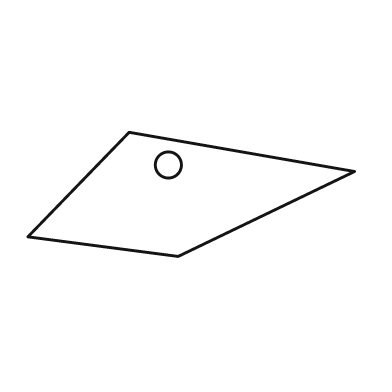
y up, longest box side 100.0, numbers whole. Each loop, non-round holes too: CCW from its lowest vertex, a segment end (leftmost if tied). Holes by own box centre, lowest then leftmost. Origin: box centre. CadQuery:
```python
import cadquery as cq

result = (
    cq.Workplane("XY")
    .moveTo(-4.0, -19.0)
    .lineTo(50.0, 7.0)
    .lineTo(-19.0, 19.0)
    .lineTo(-50.0, -13.0)
    .close()
    .moveTo(-7.0, 9.0)
    .circle(4.0)
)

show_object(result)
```